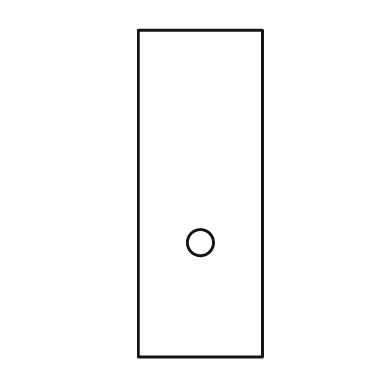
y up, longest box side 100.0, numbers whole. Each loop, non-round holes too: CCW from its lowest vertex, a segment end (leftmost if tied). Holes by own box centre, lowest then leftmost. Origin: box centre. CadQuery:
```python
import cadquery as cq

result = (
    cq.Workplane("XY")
    .moveTo(-19.0, -50.0)
    .lineTo(19.0, -50.0)
    .lineTo(19.0, 50.0)
    .lineTo(-19.0, 50.0)
    .close()
    .moveTo(0.0, -15.0)
    .circle(4.0)
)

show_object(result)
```